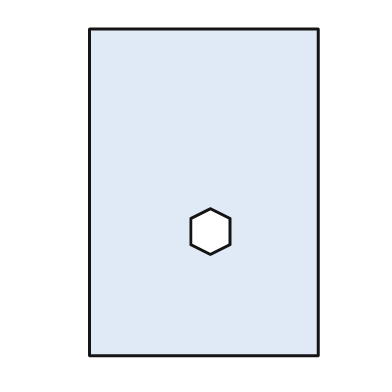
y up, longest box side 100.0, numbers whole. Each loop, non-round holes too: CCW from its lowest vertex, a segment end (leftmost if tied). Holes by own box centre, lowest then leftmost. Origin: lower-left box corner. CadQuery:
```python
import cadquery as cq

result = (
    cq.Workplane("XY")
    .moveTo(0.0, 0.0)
    .lineTo(70.0, 0.0)
    .lineTo(70.0, 100.0)
    .lineTo(0.0, 100.0)
    .close()
    .moveTo(37.0, 31.0)
    .lineTo(43.0, 34.0)
    .lineTo(43.0, 42.0)
    .lineTo(37.0, 45.0)
    .lineTo(31.0, 42.0)
    .lineTo(31.0, 34.0)
    .close()
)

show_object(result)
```